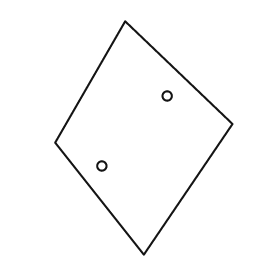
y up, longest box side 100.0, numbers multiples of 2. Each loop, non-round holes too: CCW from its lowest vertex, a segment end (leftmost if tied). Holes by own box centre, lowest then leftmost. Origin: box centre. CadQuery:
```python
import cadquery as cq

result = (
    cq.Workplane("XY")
    .moveTo(0.0, -50.0)
    .lineTo(38.0, 6.0)
    .lineTo(-8.0, 50.0)
    .lineTo(-38.0, -2.0)
    .close()
    .moveTo(-18.0, -12.0)
    .circle(2.0)
    .moveTo(10.0, 18.0)
    .circle(2.0)
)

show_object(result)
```